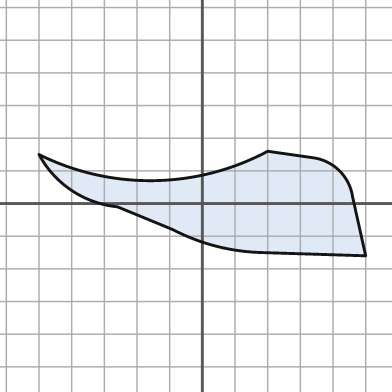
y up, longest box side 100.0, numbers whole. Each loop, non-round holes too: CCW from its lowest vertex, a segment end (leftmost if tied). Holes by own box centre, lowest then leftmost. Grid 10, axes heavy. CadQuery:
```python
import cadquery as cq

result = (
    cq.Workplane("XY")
    .moveTo(50.0, -16.0)
    .lineTo(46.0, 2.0)
    .threePointArc((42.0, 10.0), (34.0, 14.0))
    .lineTo(20.0, 16.0)
    .threePointArc((-15.0, 7.0), (-50.0, 15.0))
    .threePointArc((-40.0, 4.0), (-26.0, -1.0))
    .lineTo(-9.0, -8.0)
    .threePointArc((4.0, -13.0), (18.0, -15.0))
    .close()
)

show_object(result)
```